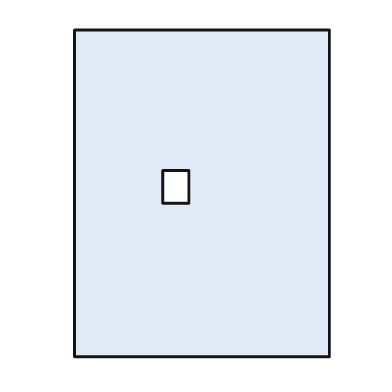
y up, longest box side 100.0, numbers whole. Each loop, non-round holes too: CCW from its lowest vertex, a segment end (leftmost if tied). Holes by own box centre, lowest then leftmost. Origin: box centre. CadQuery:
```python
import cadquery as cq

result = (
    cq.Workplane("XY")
    .moveTo(-39.0, -50.0)
    .lineTo(39.0, -50.0)
    .lineTo(39.0, 50.0)
    .lineTo(-39.0, 50.0)
    .close()
    .moveTo(-12.0, -3.0)
    .lineTo(-4.0, -3.0)
    .lineTo(-4.0, 7.0)
    .lineTo(-12.0, 7.0)
    .close()
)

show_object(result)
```